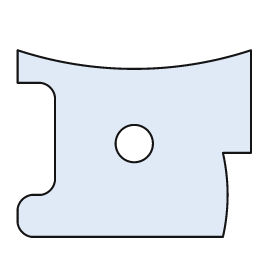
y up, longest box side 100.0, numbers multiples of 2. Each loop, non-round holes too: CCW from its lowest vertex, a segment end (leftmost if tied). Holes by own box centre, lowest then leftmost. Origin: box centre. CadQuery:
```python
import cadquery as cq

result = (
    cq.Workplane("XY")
    .moveTo(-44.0, -40.0)
    .lineTo(38.0, -40.0)
    .threePointArc((40.0, -22.0), (38.0, -4.0))
    .lineTo(50.0, -4.0)
    .lineTo(50.0, 40.0)
    .threePointArc((0.0, 32.0), (-50.0, 40.0))
    .lineTo(-50.0, 26.0)
    .lineTo(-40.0, 26.0)
    .threePointArc((-36.0, 24.0), (-34.0, 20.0))
    .lineTo(-34.0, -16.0)
    .threePointArc((-36.0, -20.0), (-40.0, -22.0))
    .lineTo(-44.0, -22.0)
    .threePointArc((-48.0, -24.0), (-50.0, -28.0))
    .lineTo(-50.0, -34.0)
    .threePointArc((-48.0, -38.0), (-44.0, -40.0))
    .close()
    .moveTo(0.0, 0.0)
    .circle(8.0)
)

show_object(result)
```